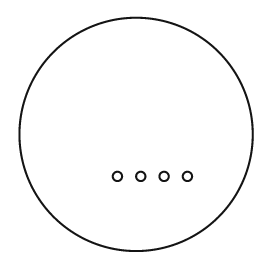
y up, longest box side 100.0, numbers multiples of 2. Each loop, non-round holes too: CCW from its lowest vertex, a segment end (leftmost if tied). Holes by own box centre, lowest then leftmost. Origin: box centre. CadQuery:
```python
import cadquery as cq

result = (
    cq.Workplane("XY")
    .moveTo(0.0, 0.0)
    .circle(50.0)
    .moveTo(-8.0, -18.0)
    .circle(2.0)
    .moveTo(2.0, -18.0)
    .circle(2.0)
    .moveTo(12.0, -18.0)
    .circle(2.0)
    .moveTo(22.0, -18.0)
    .circle(2.0)
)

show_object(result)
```